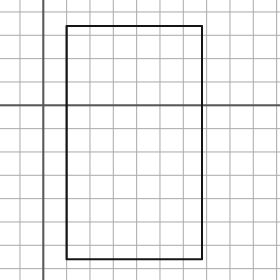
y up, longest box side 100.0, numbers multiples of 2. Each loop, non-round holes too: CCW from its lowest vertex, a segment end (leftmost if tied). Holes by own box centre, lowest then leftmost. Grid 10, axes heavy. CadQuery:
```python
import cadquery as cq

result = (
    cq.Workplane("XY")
    .moveTo(10.0, -66.0)
    .lineTo(68.0, -66.0)
    .lineTo(68.0, 34.0)
    .lineTo(10.0, 34.0)
    .close()
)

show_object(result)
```